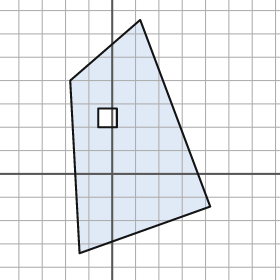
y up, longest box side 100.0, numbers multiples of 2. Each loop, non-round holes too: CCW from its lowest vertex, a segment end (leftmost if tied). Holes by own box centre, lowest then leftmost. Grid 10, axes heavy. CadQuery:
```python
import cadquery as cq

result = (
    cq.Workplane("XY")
    .moveTo(-14.0, -34.0)
    .lineTo(42.0, -14.0)
    .lineTo(12.0, 66.0)
    .lineTo(-18.0, 40.0)
    .close()
    .moveTo(-6.0, 20.0)
    .lineTo(2.0, 20.0)
    .lineTo(2.0, 28.0)
    .lineTo(-6.0, 28.0)
    .close()
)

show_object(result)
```